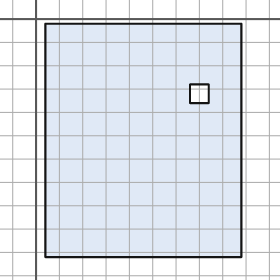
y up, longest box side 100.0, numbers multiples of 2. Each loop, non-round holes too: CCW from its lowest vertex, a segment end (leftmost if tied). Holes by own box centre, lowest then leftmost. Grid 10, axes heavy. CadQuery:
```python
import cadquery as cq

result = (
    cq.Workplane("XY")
    .moveTo(4.0, -102.0)
    .lineTo(88.0, -102.0)
    .lineTo(88.0, -2.0)
    .lineTo(4.0, -2.0)
    .close()
    .moveTo(66.0, -36.0)
    .lineTo(74.0, -36.0)
    .lineTo(74.0, -28.0)
    .lineTo(66.0, -28.0)
    .close()
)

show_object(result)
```